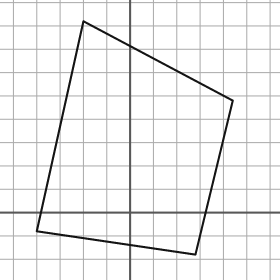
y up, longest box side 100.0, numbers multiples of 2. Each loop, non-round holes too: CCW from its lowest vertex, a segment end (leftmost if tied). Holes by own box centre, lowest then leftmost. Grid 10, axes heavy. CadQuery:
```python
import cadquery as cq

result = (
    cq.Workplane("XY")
    .moveTo(28.0, -18.0)
    .lineTo(44.0, 48.0)
    .lineTo(-20.0, 82.0)
    .lineTo(-40.0, -8.0)
    .close()
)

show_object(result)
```